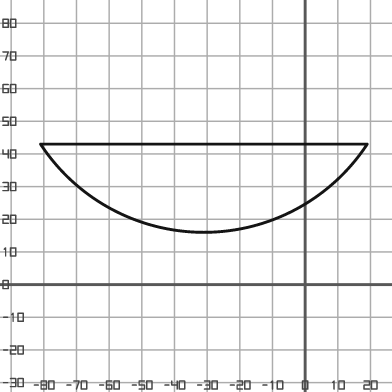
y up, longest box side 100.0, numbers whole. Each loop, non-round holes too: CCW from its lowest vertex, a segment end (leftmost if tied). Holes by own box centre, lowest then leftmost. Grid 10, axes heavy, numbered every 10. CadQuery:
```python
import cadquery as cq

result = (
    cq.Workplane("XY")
    .moveTo(-81.0, 43.0)
    .threePointArc((-31.0, 16.0), (19.0, 43.0))
    .close()
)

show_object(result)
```